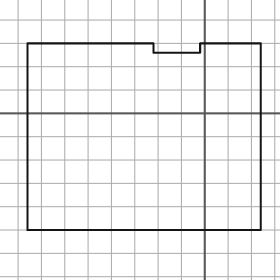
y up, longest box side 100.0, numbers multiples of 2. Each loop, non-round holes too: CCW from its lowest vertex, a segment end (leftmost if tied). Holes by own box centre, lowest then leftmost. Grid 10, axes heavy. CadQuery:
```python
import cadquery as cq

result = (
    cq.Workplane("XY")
    .moveTo(-76.0, -50.0)
    .lineTo(24.0, -50.0)
    .lineTo(24.0, 30.0)
    .lineTo(-2.0, 30.0)
    .lineTo(-2.0, 26.0)
    .lineTo(-22.0, 26.0)
    .lineTo(-22.0, 30.0)
    .lineTo(-76.0, 30.0)
    .close()
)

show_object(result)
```